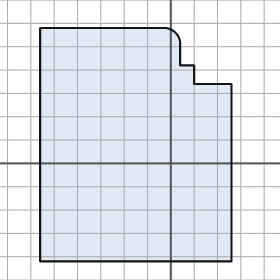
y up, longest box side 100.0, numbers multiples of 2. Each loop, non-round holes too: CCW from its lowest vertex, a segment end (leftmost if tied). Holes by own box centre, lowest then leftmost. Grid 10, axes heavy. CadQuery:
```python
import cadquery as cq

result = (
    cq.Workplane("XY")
    .moveTo(-56.0, -42.0)
    .lineTo(26.0, -42.0)
    .lineTo(26.0, 34.0)
    .lineTo(10.0, 34.0)
    .lineTo(10.0, 42.0)
    .lineTo(4.0, 42.0)
    .lineTo(4.0, 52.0)
    .threePointArc((2.0, 56.0), (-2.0, 58.0))
    .lineTo(-56.0, 58.0)
    .close()
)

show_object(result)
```